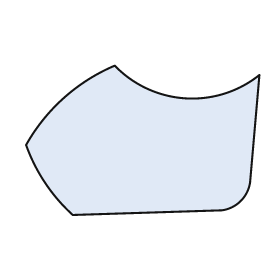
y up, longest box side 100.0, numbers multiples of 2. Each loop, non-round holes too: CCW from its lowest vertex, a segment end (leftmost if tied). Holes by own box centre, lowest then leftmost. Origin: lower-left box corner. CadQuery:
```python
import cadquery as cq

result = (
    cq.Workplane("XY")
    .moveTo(20.0, 0.0)
    .lineTo(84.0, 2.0)
    .threePointArc((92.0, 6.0), (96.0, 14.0))
    .lineTo(100.0, 60.0)
    .threePointArc((68.0, 50.0), (38.0, 64.0))
    .threePointArc((16.0, 50.0), (0.0, 30.0))
    .threePointArc((8.0, 14.0), (20.0, 0.0))
    .close()
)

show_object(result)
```